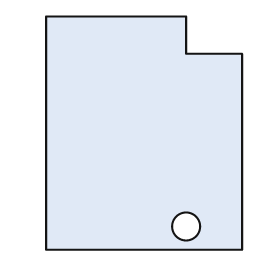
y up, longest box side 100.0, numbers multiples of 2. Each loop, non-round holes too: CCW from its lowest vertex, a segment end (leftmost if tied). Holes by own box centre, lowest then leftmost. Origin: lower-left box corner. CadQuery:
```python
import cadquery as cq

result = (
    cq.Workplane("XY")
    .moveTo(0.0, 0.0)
    .lineTo(84.0, 0.0)
    .lineTo(84.0, 84.0)
    .lineTo(60.0, 84.0)
    .lineTo(60.0, 100.0)
    .lineTo(0.0, 100.0)
    .close()
    .moveTo(60.0, 10.0)
    .circle(6.0)
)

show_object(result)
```